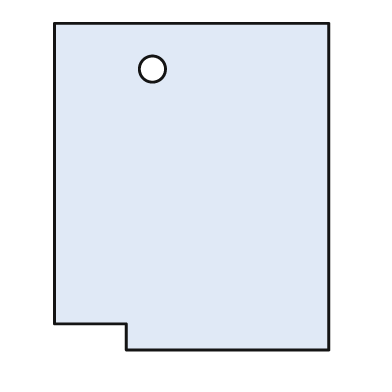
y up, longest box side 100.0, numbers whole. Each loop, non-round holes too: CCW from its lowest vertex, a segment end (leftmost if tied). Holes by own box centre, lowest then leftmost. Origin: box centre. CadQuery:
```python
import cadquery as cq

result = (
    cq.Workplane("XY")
    .moveTo(-20.0, -50.0)
    .lineTo(42.0, -50.0)
    .lineTo(42.0, 50.0)
    .lineTo(-42.0, 50.0)
    .lineTo(-42.0, -42.0)
    .lineTo(-20.0, -42.0)
    .close()
    .moveTo(-12.0, 36.0)
    .circle(4.0)
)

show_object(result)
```